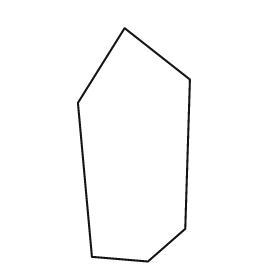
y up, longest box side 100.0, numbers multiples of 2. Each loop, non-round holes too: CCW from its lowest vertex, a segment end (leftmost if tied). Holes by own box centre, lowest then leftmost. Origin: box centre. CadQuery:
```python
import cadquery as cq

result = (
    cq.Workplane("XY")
    .moveTo(6.0, -50.0)
    .lineTo(22.0, -36.0)
    .lineTo(24.0, 28.0)
    .lineTo(-4.0, 50.0)
    .lineTo(-24.0, 18.0)
    .lineTo(-18.0, -48.0)
    .close()
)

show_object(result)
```